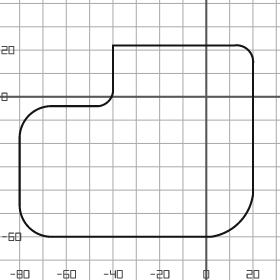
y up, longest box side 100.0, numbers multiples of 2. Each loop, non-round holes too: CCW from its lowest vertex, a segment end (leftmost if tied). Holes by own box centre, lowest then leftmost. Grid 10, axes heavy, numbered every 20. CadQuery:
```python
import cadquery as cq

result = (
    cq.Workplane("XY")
    .moveTo(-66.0, -60.0)
    .lineTo(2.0, -60.0)
    .threePointArc((14.0, -54.0), (20.0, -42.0))
    .lineTo(20.0, 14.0)
    .threePointArc((18.0, 20.0), (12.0, 22.0))
    .lineTo(-40.0, 22.0)
    .lineTo(-40.0, 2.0)
    .threePointArc((-42.0, -2.0), (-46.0, -4.0))
    .lineTo(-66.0, -4.0)
    .threePointArc((-76.0, -8.0), (-80.0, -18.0))
    .lineTo(-80.0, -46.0)
    .threePointArc((-76.0, -56.0), (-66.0, -60.0))
    .close()
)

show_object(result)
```